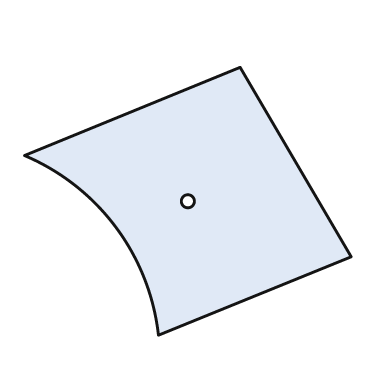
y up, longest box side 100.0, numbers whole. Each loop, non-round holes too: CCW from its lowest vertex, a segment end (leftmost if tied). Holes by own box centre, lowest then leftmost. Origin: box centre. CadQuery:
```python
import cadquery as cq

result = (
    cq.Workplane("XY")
    .moveTo(-9.0, -41.0)
    .lineTo(50.0, -17.0)
    .lineTo(16.0, 41.0)
    .lineTo(-50.0, 14.0)
    .threePointArc((-22.0, -8.0), (-9.0, -41.0))
    .close()
    .moveTo(0.0, 0.0)
    .circle(2.0)
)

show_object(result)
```